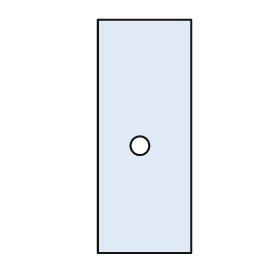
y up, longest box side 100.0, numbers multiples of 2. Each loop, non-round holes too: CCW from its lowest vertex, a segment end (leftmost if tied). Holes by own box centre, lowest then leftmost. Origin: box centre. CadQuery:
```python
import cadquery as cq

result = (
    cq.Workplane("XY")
    .moveTo(-20.0, -50.0)
    .lineTo(20.0, -50.0)
    .lineTo(20.0, 50.0)
    .lineTo(-20.0, 50.0)
    .close()
    .moveTo(-2.0, -4.0)
    .circle(4.0)
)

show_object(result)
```